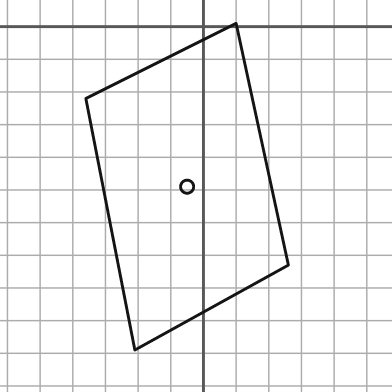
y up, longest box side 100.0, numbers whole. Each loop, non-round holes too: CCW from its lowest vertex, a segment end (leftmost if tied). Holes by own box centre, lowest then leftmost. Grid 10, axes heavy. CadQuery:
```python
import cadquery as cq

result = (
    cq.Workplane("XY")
    .moveTo(-21.0, -99.0)
    .lineTo(26.0, -73.0)
    .lineTo(10.0, 1.0)
    .lineTo(-36.0, -22.0)
    .close()
    .moveTo(-5.0, -49.0)
    .circle(2.0)
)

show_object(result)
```